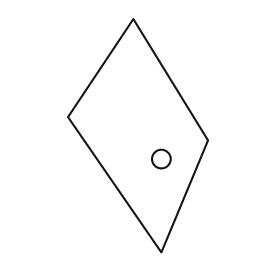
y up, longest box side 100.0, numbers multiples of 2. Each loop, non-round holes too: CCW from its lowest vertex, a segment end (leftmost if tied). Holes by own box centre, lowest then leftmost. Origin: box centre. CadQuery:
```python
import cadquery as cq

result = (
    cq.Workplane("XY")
    .moveTo(10.0, -50.0)
    .lineTo(30.0, -2.0)
    .lineTo(-2.0, 50.0)
    .lineTo(-30.0, 8.0)
    .close()
    .moveTo(10.0, -10.0)
    .circle(4.0)
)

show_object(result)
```